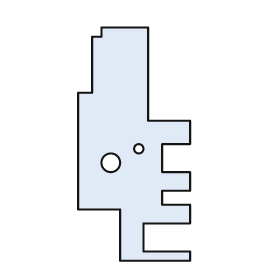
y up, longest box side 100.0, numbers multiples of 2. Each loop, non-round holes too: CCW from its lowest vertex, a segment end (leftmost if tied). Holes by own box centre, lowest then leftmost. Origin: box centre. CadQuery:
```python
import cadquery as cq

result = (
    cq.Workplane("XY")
    .moveTo(-6.0, -50.0)
    .lineTo(24.0, -50.0)
    .lineTo(24.0, -46.0)
    .lineTo(4.0, -46.0)
    .lineTo(4.0, -34.0)
    .lineTo(24.0, -34.0)
    .lineTo(24.0, -26.0)
    .lineTo(12.0, -26.0)
    .lineTo(12.0, -20.0)
    .lineTo(24.0, -20.0)
    .lineTo(24.0, -12.0)
    .lineTo(12.0, -12.0)
    .lineTo(12.0, 0.0)
    .lineTo(24.0, 0.0)
    .lineTo(24.0, 10.0)
    .lineTo(6.0, 10.0)
    .lineTo(6.0, 50.0)
    .lineTo(-14.0, 50.0)
    .lineTo(-14.0, 46.0)
    .lineTo(-18.0, 46.0)
    .lineTo(-18.0, 22.0)
    .lineTo(-24.0, 22.0)
    .lineTo(-24.0, -28.0)
    .lineTo(-6.0, -28.0)
    .close()
    .moveTo(-10.0, -8.0)
    .circle(4.0)
    .moveTo(2.0, -2.0)
    .circle(2.0)
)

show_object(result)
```